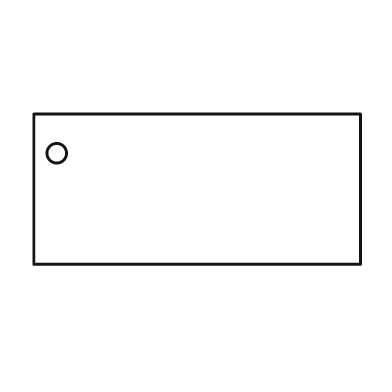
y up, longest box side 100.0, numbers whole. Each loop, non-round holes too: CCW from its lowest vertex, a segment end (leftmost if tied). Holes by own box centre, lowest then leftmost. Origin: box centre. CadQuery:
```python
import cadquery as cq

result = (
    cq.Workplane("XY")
    .moveTo(-50.0, -23.0)
    .lineTo(50.0, -23.0)
    .lineTo(50.0, 23.0)
    .lineTo(-50.0, 23.0)
    .close()
    .moveTo(-43.0, 11.0)
    .circle(3.0)
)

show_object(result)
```